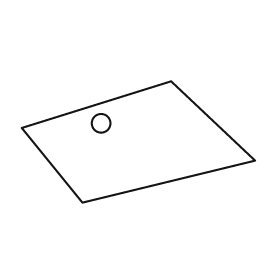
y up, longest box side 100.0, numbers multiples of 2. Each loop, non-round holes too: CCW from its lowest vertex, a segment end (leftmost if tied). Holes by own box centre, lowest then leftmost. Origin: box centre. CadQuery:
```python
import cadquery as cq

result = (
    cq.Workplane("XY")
    .moveTo(-24.0, -26.0)
    .lineTo(50.0, -8.0)
    .lineTo(14.0, 26.0)
    .lineTo(-50.0, 6.0)
    .close()
    .moveTo(-16.0, 8.0)
    .circle(4.0)
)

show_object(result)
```